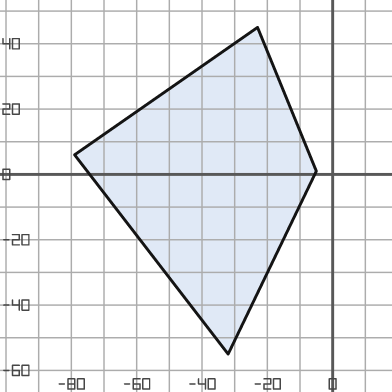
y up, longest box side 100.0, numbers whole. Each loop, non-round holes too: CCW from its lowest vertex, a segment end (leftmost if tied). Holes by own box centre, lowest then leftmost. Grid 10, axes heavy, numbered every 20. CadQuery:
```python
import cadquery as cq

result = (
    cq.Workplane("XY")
    .moveTo(-32.0, -55.0)
    .lineTo(-5.0, 1.0)
    .lineTo(-23.0, 45.0)
    .lineTo(-79.0, 6.0)
    .close()
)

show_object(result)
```